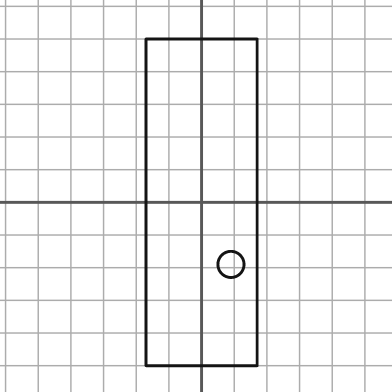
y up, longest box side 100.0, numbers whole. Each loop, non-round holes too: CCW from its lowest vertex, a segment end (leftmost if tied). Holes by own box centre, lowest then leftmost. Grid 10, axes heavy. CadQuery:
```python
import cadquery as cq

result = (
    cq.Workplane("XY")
    .moveTo(-17.0, -50.0)
    .lineTo(17.0, -50.0)
    .lineTo(17.0, 50.0)
    .lineTo(-17.0, 50.0)
    .close()
    .moveTo(9.0, -19.0)
    .circle(4.0)
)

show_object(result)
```